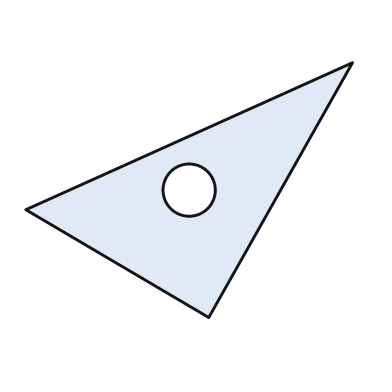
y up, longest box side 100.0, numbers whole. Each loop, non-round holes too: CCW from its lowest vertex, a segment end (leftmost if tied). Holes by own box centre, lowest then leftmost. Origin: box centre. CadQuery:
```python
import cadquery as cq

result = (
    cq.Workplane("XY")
    .moveTo(6.0, -39.0)
    .lineTo(50.0, 39.0)
    .lineTo(-50.0, -6.0)
    .close()
    .moveTo(0.0, 0.0)
    .circle(8.0)
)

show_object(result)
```